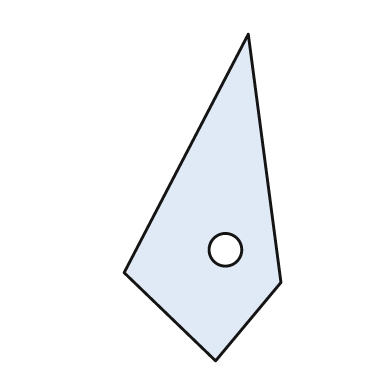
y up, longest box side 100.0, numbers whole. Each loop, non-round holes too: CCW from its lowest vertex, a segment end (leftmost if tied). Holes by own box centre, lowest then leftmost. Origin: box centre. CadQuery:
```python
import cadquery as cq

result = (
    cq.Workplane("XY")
    .moveTo(4.0, -50.0)
    .lineTo(24.0, -26.0)
    .lineTo(14.0, 50.0)
    .lineTo(-24.0, -23.0)
    .close()
    .moveTo(7.0, -16.0)
    .circle(5.0)
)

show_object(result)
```